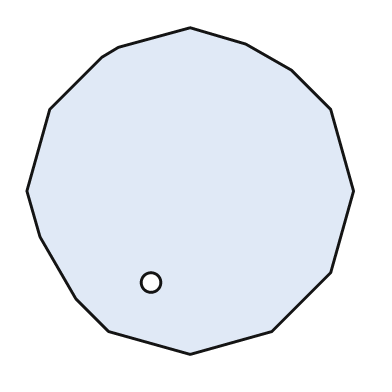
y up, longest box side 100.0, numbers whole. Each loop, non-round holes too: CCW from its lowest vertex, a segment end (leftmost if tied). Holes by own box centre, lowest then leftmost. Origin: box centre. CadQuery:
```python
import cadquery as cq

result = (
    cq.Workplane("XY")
    .moveTo(0.0, -50.0)
    .lineTo(25.0, -43.0)
    .lineTo(43.0, -25.0)
    .lineTo(50.0, 0.0)
    .lineTo(43.0, 25.0)
    .lineTo(31.0, 37.0)
    .lineTo(17.0, 45.0)
    .lineTo(0.0, 50.0)
    .lineTo(-22.0, 44.0)
    .lineTo(-27.0, 41.0)
    .lineTo(-43.0, 25.0)
    .lineTo(-50.0, 0.0)
    .lineTo(-46.0, -14.0)
    .lineTo(-35.0, -33.0)
    .lineTo(-25.0, -43.0)
    .close()
    .moveTo(-12.0, -28.0)
    .circle(3.0)
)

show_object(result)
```